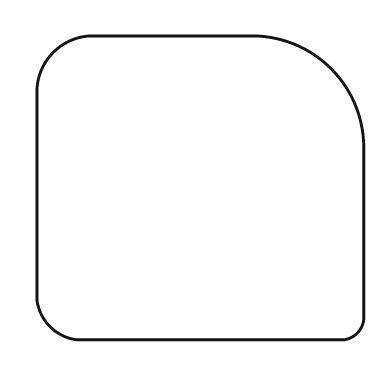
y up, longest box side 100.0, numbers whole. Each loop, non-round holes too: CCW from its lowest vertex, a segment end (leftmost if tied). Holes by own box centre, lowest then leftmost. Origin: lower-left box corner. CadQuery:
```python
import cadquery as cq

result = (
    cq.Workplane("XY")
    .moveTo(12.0, 0.0)
    .lineTo(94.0, 0.0)
    .threePointArc((98.0, 2.0), (100.0, 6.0))
    .lineTo(100.0, 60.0)
    .threePointArc((90.0, 83.0), (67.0, 93.0))
    .lineTo(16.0, 93.0)
    .threePointArc((5.0, 88.0), (0.0, 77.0))
    .lineTo(0.0, 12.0)
    .threePointArc((4.0, 4.0), (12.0, 0.0))
    .close()
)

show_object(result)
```